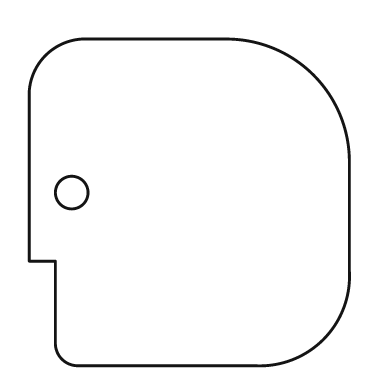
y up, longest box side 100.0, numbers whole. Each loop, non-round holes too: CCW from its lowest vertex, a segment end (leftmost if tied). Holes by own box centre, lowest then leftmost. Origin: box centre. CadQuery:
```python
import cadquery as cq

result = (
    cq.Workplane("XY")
    .moveTo(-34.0, -50.0)
    .lineTo(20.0, -50.0)
    .threePointArc((41.0, -42.0), (49.0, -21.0))
    .lineTo(49.0, 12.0)
    .threePointArc((38.0, 39.0), (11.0, 50.0))
    .lineTo(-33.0, 50.0)
    .threePointArc((-44.0, 45.0), (-49.0, 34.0))
    .lineTo(-49.0, -18.0)
    .lineTo(-41.0, -18.0)
    .lineTo(-41.0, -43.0)
    .threePointArc((-39.0, -48.0), (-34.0, -50.0))
    .close()
    .moveTo(-36.0, 3.0)
    .circle(5.0)
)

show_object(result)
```